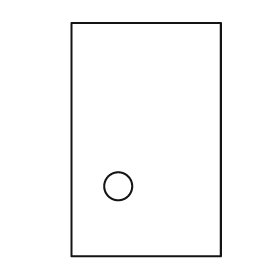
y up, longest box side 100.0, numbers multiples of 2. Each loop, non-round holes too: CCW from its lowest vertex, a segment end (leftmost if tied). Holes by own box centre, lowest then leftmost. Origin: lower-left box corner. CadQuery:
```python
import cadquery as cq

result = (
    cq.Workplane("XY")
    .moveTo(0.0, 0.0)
    .lineTo(64.0, 0.0)
    .lineTo(64.0, 100.0)
    .lineTo(0.0, 100.0)
    .close()
    .moveTo(20.0, 30.0)
    .circle(6.0)
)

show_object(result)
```